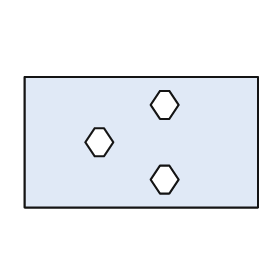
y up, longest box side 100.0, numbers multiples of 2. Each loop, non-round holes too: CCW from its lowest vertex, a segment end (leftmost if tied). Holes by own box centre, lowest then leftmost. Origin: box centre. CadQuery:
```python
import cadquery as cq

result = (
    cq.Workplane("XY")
    .moveTo(-50.0, -28.0)
    .lineTo(50.0, -28.0)
    .lineTo(50.0, 28.0)
    .lineTo(-50.0, 28.0)
    .close()
    .moveTo(8.0, -22.0)
    .lineTo(12.0, -22.0)
    .lineTo(16.0, -16.0)
    .lineTo(12.0, -10.0)
    .lineTo(8.0, -10.0)
    .lineTo(4.0, -16.0)
    .close()
    .moveTo(-20.0, -6.0)
    .lineTo(-16.0, -6.0)
    .lineTo(-12.0, 0.0)
    .lineTo(-16.0, 6.0)
    .lineTo(-20.0, 6.0)
    .lineTo(-24.0, 0.0)
    .close()
    .moveTo(8.0, 10.0)
    .lineTo(12.0, 10.0)
    .lineTo(16.0, 16.0)
    .lineTo(12.0, 22.0)
    .lineTo(8.0, 22.0)
    .lineTo(4.0, 16.0)
    .close()
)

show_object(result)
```